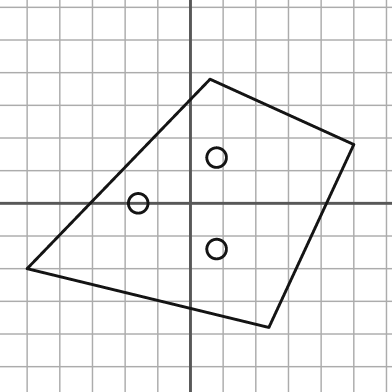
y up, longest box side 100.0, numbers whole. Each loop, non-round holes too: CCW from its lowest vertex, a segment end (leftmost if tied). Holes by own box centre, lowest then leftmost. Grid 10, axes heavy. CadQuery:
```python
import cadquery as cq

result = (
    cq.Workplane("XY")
    .moveTo(24.0, -38.0)
    .lineTo(50.0, 18.0)
    .lineTo(6.0, 38.0)
    .lineTo(-50.0, -20.0)
    .close()
    .moveTo(8.0, -14.0)
    .circle(3.0)
    .moveTo(-16.0, 0.0)
    .circle(3.0)
    .moveTo(8.0, 14.0)
    .circle(3.0)
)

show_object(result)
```